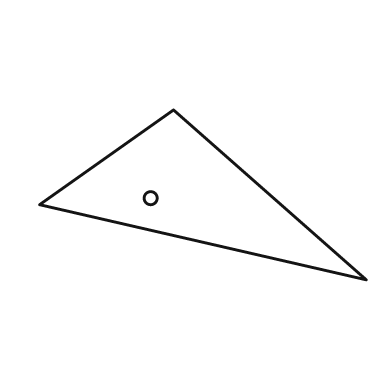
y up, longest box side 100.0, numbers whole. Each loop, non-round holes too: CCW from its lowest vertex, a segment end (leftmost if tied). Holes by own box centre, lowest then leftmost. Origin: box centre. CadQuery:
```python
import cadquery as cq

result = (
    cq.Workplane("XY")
    .moveTo(50.0, -26.0)
    .lineTo(-9.0, 26.0)
    .lineTo(-50.0, -3.0)
    .close()
    .moveTo(-16.0, -1.0)
    .circle(2.0)
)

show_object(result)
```